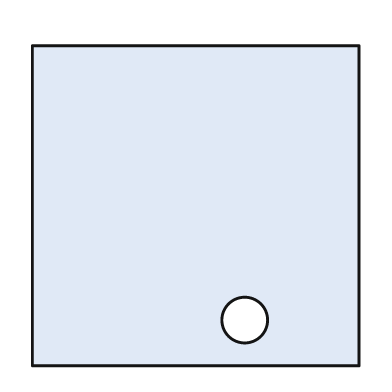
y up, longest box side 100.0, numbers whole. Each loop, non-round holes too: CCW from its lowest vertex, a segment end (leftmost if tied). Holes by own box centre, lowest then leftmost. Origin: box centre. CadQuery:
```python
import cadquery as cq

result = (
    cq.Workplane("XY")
    .moveTo(-50.0, -49.0)
    .lineTo(50.0, -49.0)
    .lineTo(50.0, 49.0)
    .lineTo(-50.0, 49.0)
    .close()
    .moveTo(15.0, -35.0)
    .circle(7.0)
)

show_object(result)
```